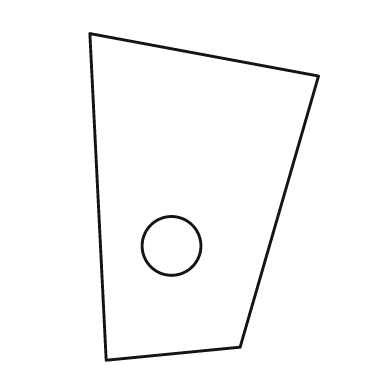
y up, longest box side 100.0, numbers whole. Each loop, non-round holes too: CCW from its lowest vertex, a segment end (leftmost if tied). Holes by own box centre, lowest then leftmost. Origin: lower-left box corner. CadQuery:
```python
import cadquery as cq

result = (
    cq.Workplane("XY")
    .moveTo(5.0, 0.0)
    .lineTo(46.0, 4.0)
    .lineTo(70.0, 87.0)
    .lineTo(0.0, 100.0)
    .close()
    .moveTo(25.0, 35.0)
    .circle(9.0)
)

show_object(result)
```